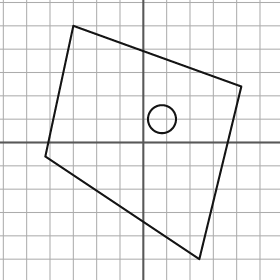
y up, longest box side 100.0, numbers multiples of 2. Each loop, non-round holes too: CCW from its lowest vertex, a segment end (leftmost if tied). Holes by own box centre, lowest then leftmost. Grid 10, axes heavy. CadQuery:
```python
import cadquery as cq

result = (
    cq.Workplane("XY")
    .moveTo(24.0, -50.0)
    .lineTo(42.0, 24.0)
    .lineTo(-30.0, 50.0)
    .lineTo(-42.0, -6.0)
    .close()
    .moveTo(8.0, 10.0)
    .circle(6.0)
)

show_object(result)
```